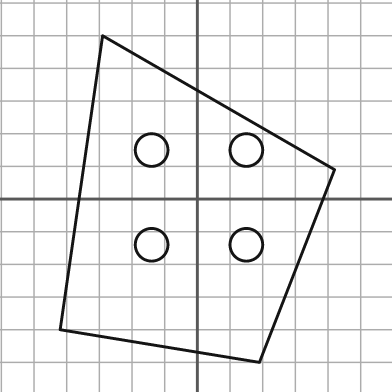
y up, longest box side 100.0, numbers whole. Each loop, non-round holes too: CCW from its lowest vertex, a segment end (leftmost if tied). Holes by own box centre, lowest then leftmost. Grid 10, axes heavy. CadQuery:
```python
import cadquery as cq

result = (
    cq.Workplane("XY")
    .moveTo(19.0, -50.0)
    .lineTo(42.0, 9.0)
    .lineTo(-29.0, 50.0)
    .lineTo(-42.0, -40.0)
    .close()
    .moveTo(-14.0, -14.0)
    .circle(5.0)
    .moveTo(15.0, -14.0)
    .circle(5.0)
    .moveTo(-14.0, 15.0)
    .circle(5.0)
    .moveTo(15.0, 15.0)
    .circle(5.0)
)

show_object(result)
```